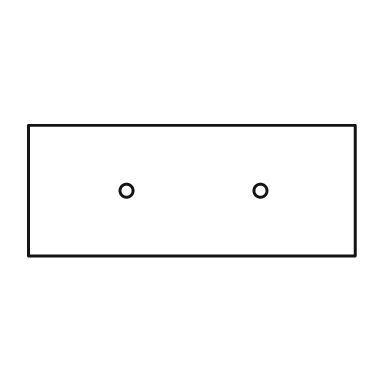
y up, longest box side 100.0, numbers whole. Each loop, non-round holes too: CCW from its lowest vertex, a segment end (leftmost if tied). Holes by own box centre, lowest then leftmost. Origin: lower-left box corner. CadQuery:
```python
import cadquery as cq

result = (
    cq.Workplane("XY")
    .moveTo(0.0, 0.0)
    .lineTo(100.0, 0.0)
    .lineTo(100.0, 40.0)
    .lineTo(0.0, 40.0)
    .close()
    .moveTo(30.0, 20.0)
    .circle(2.0)
    .moveTo(71.0, 20.0)
    .circle(2.0)
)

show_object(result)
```